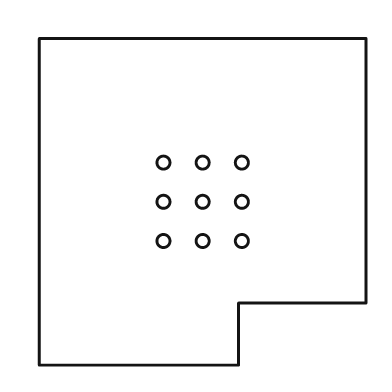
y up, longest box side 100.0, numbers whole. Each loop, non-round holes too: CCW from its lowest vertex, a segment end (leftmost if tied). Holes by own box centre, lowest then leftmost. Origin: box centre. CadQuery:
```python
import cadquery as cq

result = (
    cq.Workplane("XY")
    .moveTo(-50.0, -50.0)
    .lineTo(11.0, -50.0)
    .lineTo(11.0, -31.0)
    .lineTo(50.0, -31.0)
    .lineTo(50.0, 50.0)
    .lineTo(-50.0, 50.0)
    .close()
    .moveTo(-12.0, -12.0)
    .circle(2.0)
    .moveTo(0.0, -12.0)
    .circle(2.0)
    .moveTo(12.0, -12.0)
    .circle(2.0)
    .moveTo(-12.0, 0.0)
    .circle(2.0)
    .moveTo(0.0, 0.0)
    .circle(2.0)
    .moveTo(12.0, 0.0)
    .circle(2.0)
    .moveTo(-12.0, 12.0)
    .circle(2.0)
    .moveTo(0.0, 12.0)
    .circle(2.0)
    .moveTo(12.0, 12.0)
    .circle(2.0)
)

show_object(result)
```